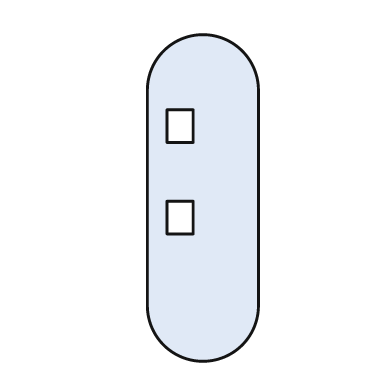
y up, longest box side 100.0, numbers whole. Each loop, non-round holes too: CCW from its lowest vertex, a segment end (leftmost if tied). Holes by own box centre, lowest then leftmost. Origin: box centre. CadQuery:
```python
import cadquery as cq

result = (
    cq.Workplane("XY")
    .moveTo(-17.0, -33.0)
    .threePointArc((0.0, -50.0), (17.0, -33.0))
    .lineTo(17.0, 33.0)
    .threePointArc((0.0, 50.0), (-17.0, 33.0))
    .close()
    .moveTo(-11.0, -11.0)
    .lineTo(-3.0, -11.0)
    .lineTo(-3.0, -1.0)
    .lineTo(-11.0, -1.0)
    .close()
    .moveTo(-11.0, 17.0)
    .lineTo(-3.0, 17.0)
    .lineTo(-3.0, 27.0)
    .lineTo(-11.0, 27.0)
    .close()
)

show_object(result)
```